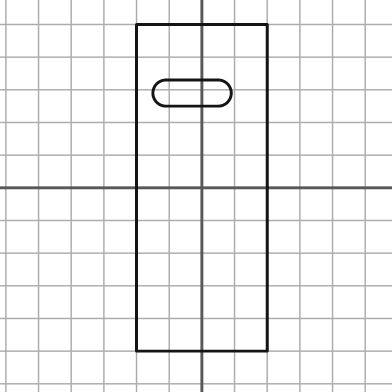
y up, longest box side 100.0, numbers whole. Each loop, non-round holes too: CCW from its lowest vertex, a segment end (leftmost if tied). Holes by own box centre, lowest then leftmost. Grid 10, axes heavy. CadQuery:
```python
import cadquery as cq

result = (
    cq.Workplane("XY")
    .moveTo(-20.0, -50.0)
    .lineTo(20.0, -50.0)
    .lineTo(20.0, 50.0)
    .lineTo(-20.0, 50.0)
    .close()
    .moveTo(-11.0, 25.0)
    .lineTo(5.0, 25.0)
    .threePointArc((9.0, 29.0), (5.0, 33.0))
    .lineTo(-11.0, 33.0)
    .threePointArc((-15.0, 29.0), (-11.0, 25.0))
    .close()
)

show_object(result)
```